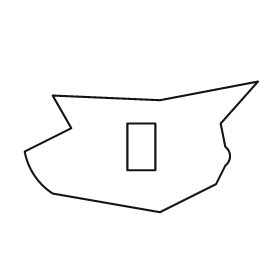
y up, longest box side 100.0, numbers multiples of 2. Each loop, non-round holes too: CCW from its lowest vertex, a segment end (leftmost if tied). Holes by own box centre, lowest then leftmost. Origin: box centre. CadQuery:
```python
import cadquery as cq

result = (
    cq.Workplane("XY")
    .moveTo(8.0, -28.0)
    .lineTo(32.0, -16.0)
    .lineTo(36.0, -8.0)
    .threePointArc((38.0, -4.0), (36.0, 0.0))
    .lineTo(34.0, 10.0)
    .lineTo(50.0, 28.0)
    .lineTo(8.0, 20.0)
    .lineTo(-38.0, 22.0)
    .lineTo(-30.0, 8.0)
    .lineTo(-50.0, -2.0)
    .threePointArc((-46.0, -12.0), (-38.0, -20.0))
    .close()
    .moveTo(-6.0, -10.0)
    .lineTo(6.0, -10.0)
    .lineTo(6.0, 10.0)
    .lineTo(-6.0, 10.0)
    .close()
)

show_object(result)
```